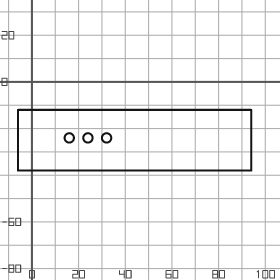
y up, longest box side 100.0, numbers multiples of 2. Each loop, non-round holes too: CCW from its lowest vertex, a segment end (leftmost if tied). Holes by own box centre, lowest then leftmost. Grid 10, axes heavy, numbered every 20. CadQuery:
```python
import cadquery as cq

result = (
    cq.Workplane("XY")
    .moveTo(-6.0, -38.0)
    .lineTo(94.0, -38.0)
    .lineTo(94.0, -12.0)
    .lineTo(-6.0, -12.0)
    .close()
    .moveTo(16.0, -24.0)
    .circle(2.0)
    .moveTo(24.0, -24.0)
    .circle(2.0)
    .moveTo(32.0, -24.0)
    .circle(2.0)
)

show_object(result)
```